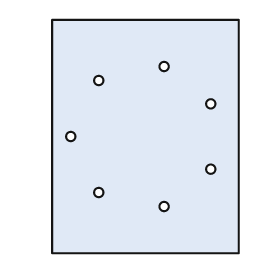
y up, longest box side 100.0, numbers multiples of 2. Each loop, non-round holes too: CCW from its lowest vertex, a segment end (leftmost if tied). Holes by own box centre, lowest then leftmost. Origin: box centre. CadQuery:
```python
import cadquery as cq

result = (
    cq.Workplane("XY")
    .moveTo(-40.0, -50.0)
    .lineTo(40.0, -50.0)
    .lineTo(40.0, 50.0)
    .lineTo(-40.0, 50.0)
    .close()
    .moveTo(8.0, -30.0)
    .circle(2.0)
    .moveTo(-20.0, -24.0)
    .circle(2.0)
    .moveTo(28.0, -14.0)
    .circle(2.0)
    .moveTo(-32.0, 0.0)
    .circle(2.0)
    .moveTo(28.0, 14.0)
    .circle(2.0)
    .moveTo(-20.0, 24.0)
    .circle(2.0)
    .moveTo(8.0, 30.0)
    .circle(2.0)
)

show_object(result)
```